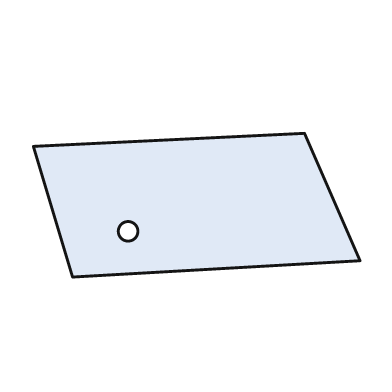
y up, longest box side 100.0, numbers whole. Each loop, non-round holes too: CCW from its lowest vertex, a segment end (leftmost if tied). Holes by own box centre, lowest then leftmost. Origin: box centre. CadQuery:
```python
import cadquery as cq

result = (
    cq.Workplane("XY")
    .moveTo(-38.0, -22.0)
    .lineTo(50.0, -17.0)
    .lineTo(33.0, 22.0)
    .lineTo(-50.0, 18.0)
    .close()
    .moveTo(-21.0, -8.0)
    .circle(3.0)
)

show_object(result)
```